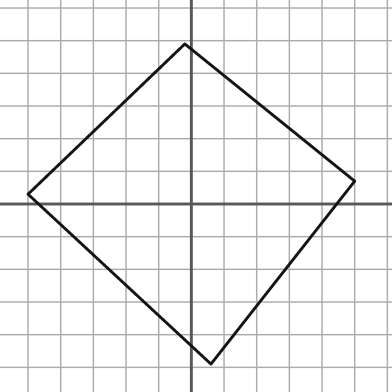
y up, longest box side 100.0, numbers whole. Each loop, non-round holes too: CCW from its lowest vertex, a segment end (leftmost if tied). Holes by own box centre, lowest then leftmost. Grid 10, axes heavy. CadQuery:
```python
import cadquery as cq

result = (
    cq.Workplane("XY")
    .moveTo(6.0, -49.0)
    .lineTo(50.0, 7.0)
    .lineTo(-2.0, 49.0)
    .lineTo(-50.0, 3.0)
    .close()
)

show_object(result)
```